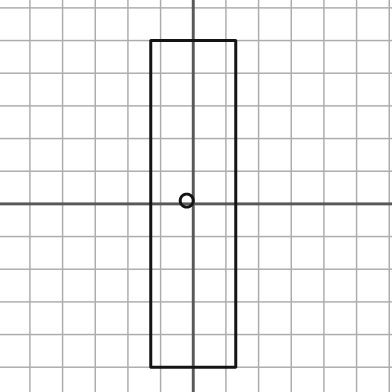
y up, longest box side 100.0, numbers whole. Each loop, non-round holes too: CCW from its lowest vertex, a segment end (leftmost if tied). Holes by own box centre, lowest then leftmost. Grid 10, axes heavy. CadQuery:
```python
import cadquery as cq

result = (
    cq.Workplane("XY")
    .moveTo(-13.0, -50.0)
    .lineTo(13.0, -50.0)
    .lineTo(13.0, 50.0)
    .lineTo(-13.0, 50.0)
    .close()
    .moveTo(-2.0, 1.0)
    .circle(2.0)
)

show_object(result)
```